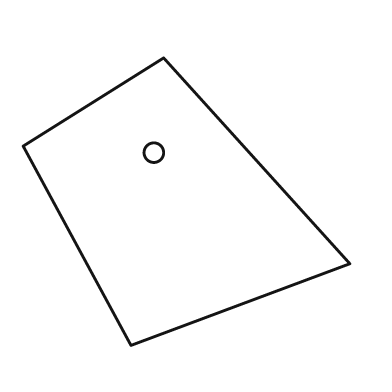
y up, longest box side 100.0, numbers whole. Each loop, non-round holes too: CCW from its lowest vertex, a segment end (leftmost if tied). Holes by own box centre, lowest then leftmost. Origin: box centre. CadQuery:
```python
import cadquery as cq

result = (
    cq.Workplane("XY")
    .moveTo(-17.0, -44.0)
    .lineTo(50.0, -19.0)
    .lineTo(-7.0, 44.0)
    .lineTo(-50.0, 17.0)
    .close()
    .moveTo(-10.0, 15.0)
    .circle(3.0)
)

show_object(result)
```